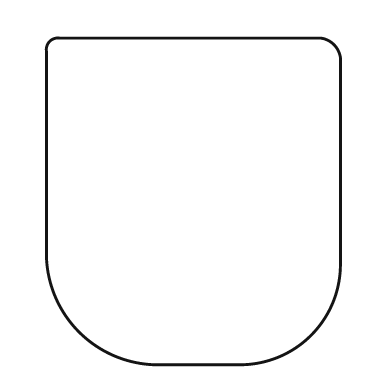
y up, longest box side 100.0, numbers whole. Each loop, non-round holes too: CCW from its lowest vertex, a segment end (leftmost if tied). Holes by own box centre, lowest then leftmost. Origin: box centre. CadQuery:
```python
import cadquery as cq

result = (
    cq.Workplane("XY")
    .moveTo(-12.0, -50.0)
    .lineTo(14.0, -50.0)
    .threePointArc((36.0, -41.0), (45.0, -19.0))
    .lineTo(45.0, 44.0)
    .threePointArc((43.0, 48.0), (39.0, 50.0))
    .lineTo(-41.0, 50.0)
    .threePointArc((-44.0, 49.0), (-45.0, 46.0))
    .lineTo(-45.0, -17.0)
    .threePointArc((-35.0, -40.0), (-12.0, -50.0))
    .close()
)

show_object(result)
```